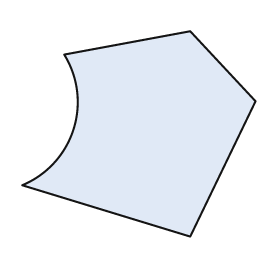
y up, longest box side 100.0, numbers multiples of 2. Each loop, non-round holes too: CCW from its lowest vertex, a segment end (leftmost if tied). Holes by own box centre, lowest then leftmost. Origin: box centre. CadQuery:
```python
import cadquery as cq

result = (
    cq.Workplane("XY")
    .moveTo(22.0, -44.0)
    .lineTo(50.0, 14.0)
    .lineTo(22.0, 44.0)
    .lineTo(-32.0, 34.0)
    .threePointArc((-28.0, 2.0), (-50.0, -22.0))
    .close()
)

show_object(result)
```